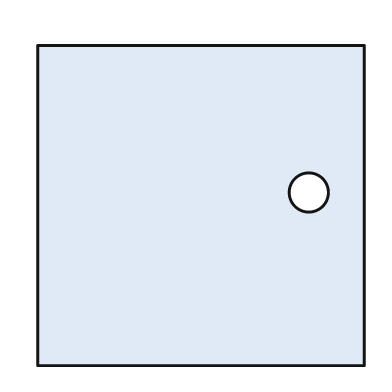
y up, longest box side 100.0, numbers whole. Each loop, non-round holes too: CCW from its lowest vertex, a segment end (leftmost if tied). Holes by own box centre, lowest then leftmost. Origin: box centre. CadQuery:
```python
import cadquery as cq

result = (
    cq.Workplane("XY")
    .moveTo(-50.0, -49.0)
    .lineTo(50.0, -49.0)
    .lineTo(50.0, 49.0)
    .lineTo(-50.0, 49.0)
    .close()
    .moveTo(33.0, 4.0)
    .circle(6.0)
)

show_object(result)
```